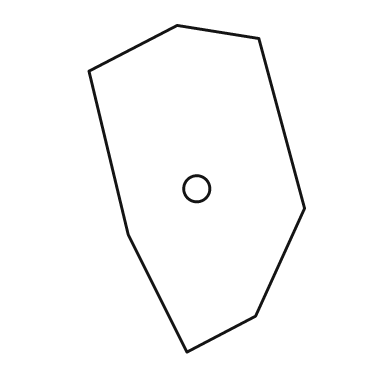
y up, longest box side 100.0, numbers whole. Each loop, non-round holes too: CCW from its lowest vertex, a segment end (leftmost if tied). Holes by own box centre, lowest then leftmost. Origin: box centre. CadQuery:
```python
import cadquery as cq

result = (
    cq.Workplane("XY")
    .moveTo(-3.0, -50.0)
    .lineTo(18.0, -39.0)
    .lineTo(33.0, -6.0)
    .lineTo(19.0, 46.0)
    .lineTo(-6.0, 50.0)
    .lineTo(-33.0, 36.0)
    .lineTo(-21.0, -14.0)
    .close()
    .moveTo(0.0, 0.0)
    .circle(4.0)
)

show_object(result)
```